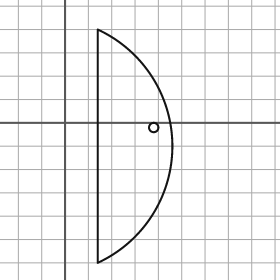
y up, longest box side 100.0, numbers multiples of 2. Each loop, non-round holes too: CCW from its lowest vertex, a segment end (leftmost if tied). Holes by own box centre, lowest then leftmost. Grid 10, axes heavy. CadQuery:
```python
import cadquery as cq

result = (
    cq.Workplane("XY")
    .moveTo(14.0, -60.0)
    .threePointArc((46.0, -10.0), (14.0, 40.0))
    .close()
    .moveTo(38.0, -2.0)
    .circle(2.0)
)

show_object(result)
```